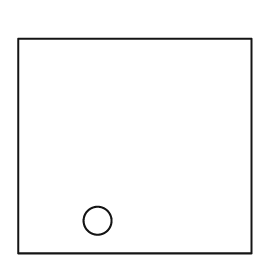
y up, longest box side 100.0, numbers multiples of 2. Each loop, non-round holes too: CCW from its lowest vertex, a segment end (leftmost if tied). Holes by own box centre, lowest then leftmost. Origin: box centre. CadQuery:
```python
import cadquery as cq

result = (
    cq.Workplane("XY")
    .moveTo(-50.0, -46.0)
    .lineTo(50.0, -46.0)
    .lineTo(50.0, 46.0)
    .lineTo(-50.0, 46.0)
    .close()
    .moveTo(-16.0, -32.0)
    .circle(6.0)
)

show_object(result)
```